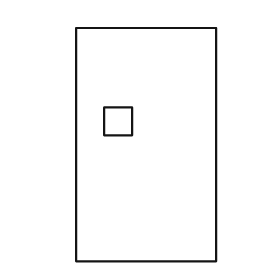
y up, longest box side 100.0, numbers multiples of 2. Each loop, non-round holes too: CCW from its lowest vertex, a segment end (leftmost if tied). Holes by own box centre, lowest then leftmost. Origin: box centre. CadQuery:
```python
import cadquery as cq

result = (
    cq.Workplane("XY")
    .moveTo(-30.0, -50.0)
    .lineTo(30.0, -50.0)
    .lineTo(30.0, 50.0)
    .lineTo(-30.0, 50.0)
    .close()
    .moveTo(-18.0, 4.0)
    .lineTo(-6.0, 4.0)
    .lineTo(-6.0, 16.0)
    .lineTo(-18.0, 16.0)
    .close()
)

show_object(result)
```